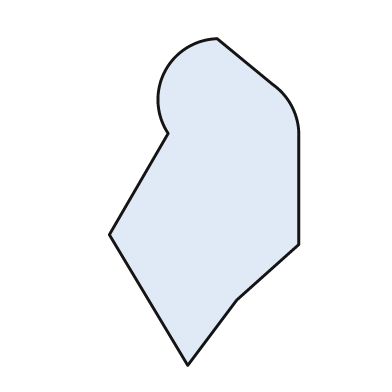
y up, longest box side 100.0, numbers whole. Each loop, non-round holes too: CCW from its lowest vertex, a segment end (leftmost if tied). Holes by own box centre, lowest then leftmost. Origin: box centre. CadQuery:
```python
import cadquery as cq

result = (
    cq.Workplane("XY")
    .moveTo(-5.0, -50.0)
    .lineTo(10.0, -30.0)
    .lineTo(29.0, -13.0)
    .lineTo(29.0, 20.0)
    .threePointArc((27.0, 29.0), (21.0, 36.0))
    .lineTo(4.0, 50.0)
    .threePointArc((-12.0, 40.0), (-11.0, 21.0))
    .lineTo(-29.0, -10.0)
    .close()
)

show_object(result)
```